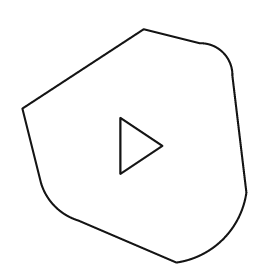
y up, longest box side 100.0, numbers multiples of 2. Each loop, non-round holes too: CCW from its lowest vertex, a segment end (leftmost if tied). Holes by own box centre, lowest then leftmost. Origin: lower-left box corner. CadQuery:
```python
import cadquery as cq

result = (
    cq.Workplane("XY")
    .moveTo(66.0, 0.0)
    .threePointArc((86.0, 10.0), (96.0, 30.0))
    .lineTo(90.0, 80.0)
    .threePointArc((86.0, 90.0), (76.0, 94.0))
    .lineTo(52.0, 100.0)
    .lineTo(0.0, 66.0)
    .lineTo(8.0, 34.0)
    .threePointArc((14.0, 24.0), (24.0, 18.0))
    .close()
    .moveTo(42.0, 38.0)
    .lineTo(60.0, 50.0)
    .lineTo(42.0, 62.0)
    .close()
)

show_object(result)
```